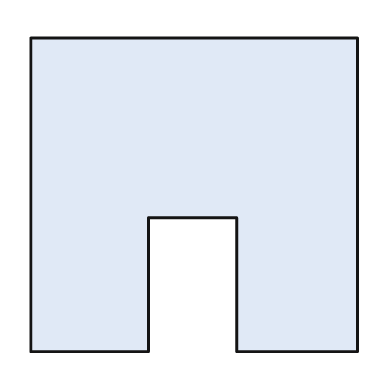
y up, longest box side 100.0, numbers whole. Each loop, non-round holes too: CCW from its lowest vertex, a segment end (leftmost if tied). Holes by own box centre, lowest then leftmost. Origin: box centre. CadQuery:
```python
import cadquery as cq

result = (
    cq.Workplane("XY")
    .moveTo(-50.0, -48.0)
    .lineTo(-14.0, -48.0)
    .lineTo(-14.0, -7.0)
    .lineTo(13.0, -7.0)
    .lineTo(13.0, -48.0)
    .lineTo(50.0, -48.0)
    .lineTo(50.0, 48.0)
    .lineTo(-50.0, 48.0)
    .close()
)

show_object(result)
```